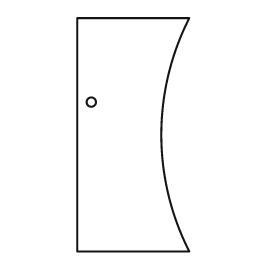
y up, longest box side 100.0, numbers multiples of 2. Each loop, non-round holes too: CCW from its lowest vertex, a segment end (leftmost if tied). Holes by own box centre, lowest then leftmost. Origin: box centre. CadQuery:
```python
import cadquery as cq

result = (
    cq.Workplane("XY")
    .moveTo(-24.0, -50.0)
    .lineTo(24.0, -50.0)
    .threePointArc((12.0, 0.0), (24.0, 50.0))
    .lineTo(-24.0, 50.0)
    .close()
    .moveTo(-18.0, 14.0)
    .circle(2.0)
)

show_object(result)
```